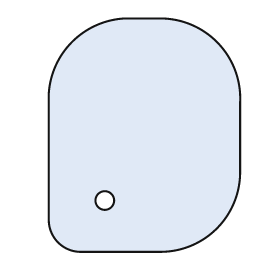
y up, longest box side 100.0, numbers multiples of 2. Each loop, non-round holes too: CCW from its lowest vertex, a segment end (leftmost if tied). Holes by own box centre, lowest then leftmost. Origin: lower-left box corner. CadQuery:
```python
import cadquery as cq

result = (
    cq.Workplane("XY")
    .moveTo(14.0, 0.0)
    .lineTo(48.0, 0.0)
    .threePointArc((72.0, 10.0), (82.0, 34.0))
    .lineTo(82.0, 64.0)
    .threePointArc((72.0, 90.0), (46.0, 100.0))
    .lineTo(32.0, 100.0)
    .threePointArc((10.0, 90.0), (0.0, 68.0))
    .lineTo(0.0, 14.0)
    .threePointArc((4.0, 4.0), (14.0, 0.0))
    .close()
    .moveTo(24.0, 22.0)
    .circle(4.0)
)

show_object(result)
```